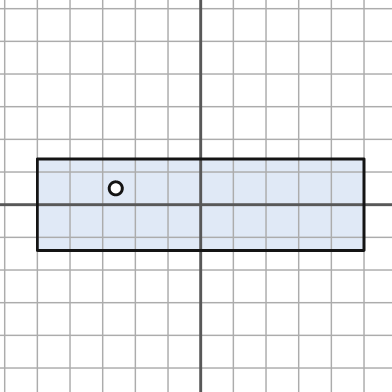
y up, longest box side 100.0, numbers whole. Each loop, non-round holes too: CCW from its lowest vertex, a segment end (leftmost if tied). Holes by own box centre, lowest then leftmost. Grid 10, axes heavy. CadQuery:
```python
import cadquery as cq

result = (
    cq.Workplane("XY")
    .moveTo(-50.0, -14.0)
    .lineTo(50.0, -14.0)
    .lineTo(50.0, 14.0)
    .lineTo(-50.0, 14.0)
    .close()
    .moveTo(-26.0, 5.0)
    .circle(2.0)
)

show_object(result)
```